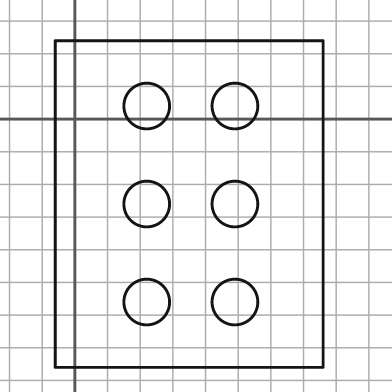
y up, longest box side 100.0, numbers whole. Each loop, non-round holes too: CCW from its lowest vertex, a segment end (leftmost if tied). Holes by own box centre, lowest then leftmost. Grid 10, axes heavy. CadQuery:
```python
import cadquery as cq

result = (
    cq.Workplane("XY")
    .moveTo(-6.0, -76.0)
    .lineTo(76.0, -76.0)
    .lineTo(76.0, 24.0)
    .lineTo(-6.0, 24.0)
    .close()
    .moveTo(22.0, -56.0)
    .circle(7.0)
    .moveTo(49.0, -56.0)
    .circle(7.0)
    .moveTo(22.0, -26.0)
    .circle(7.0)
    .moveTo(49.0, -26.0)
    .circle(7.0)
    .moveTo(22.0, 4.0)
    .circle(7.0)
    .moveTo(49.0, 4.0)
    .circle(7.0)
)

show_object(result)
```